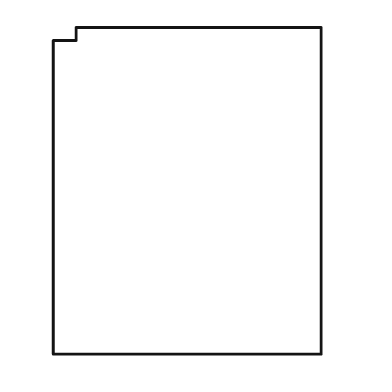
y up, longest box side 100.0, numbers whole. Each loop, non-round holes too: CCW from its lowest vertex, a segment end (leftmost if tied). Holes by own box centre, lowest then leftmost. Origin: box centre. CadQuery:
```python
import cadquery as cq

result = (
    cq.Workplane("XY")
    .moveTo(-41.0, -50.0)
    .lineTo(41.0, -50.0)
    .lineTo(41.0, 50.0)
    .lineTo(-34.0, 50.0)
    .lineTo(-34.0, 46.0)
    .lineTo(-41.0, 46.0)
    .close()
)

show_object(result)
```